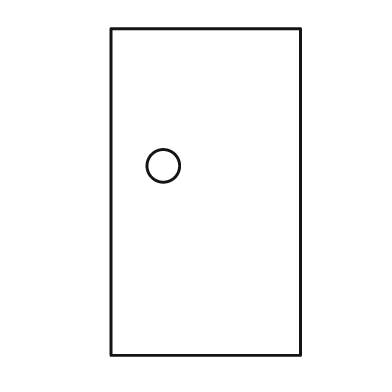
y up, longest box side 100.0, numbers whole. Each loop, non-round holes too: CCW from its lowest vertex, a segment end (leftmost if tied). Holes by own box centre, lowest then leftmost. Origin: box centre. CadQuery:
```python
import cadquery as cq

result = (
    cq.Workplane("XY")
    .moveTo(-29.0, -50.0)
    .lineTo(29.0, -50.0)
    .lineTo(29.0, 50.0)
    .lineTo(-29.0, 50.0)
    .close()
    .moveTo(-13.0, 8.0)
    .circle(5.0)
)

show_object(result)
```